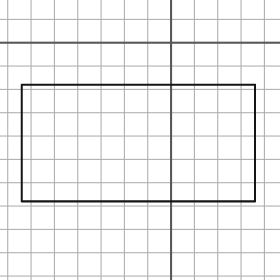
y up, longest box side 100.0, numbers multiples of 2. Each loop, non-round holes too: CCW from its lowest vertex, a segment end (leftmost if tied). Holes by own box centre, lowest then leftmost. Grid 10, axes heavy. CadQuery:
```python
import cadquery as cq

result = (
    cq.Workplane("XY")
    .moveTo(-64.0, -68.0)
    .lineTo(36.0, -68.0)
    .lineTo(36.0, -18.0)
    .lineTo(-64.0, -18.0)
    .close()
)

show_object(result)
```